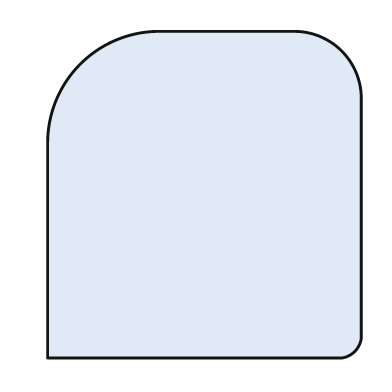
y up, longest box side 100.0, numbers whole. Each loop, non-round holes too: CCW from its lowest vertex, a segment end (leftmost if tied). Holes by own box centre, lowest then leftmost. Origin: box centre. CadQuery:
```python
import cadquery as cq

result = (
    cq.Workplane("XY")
    .moveTo(-48.0, -50.0)
    .lineTo(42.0, -50.0)
    .threePointArc((46.0, -48.0), (48.0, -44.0))
    .lineTo(48.0, 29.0)
    .threePointArc((42.0, 44.0), (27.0, 50.0))
    .lineTo(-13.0, 50.0)
    .threePointArc((-38.0, 40.0), (-48.0, 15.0))
    .close()
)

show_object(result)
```